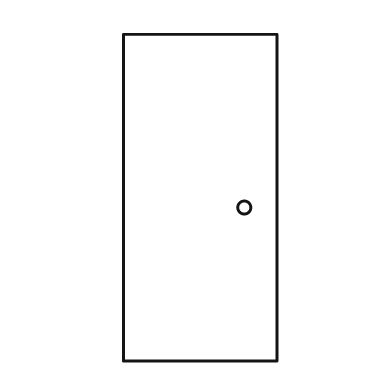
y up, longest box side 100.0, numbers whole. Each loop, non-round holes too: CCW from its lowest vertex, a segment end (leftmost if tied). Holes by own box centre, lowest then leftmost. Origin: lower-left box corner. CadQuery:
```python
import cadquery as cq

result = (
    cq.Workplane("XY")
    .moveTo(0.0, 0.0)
    .lineTo(47.0, 0.0)
    .lineTo(47.0, 100.0)
    .lineTo(0.0, 100.0)
    .close()
    .moveTo(37.0, 47.0)
    .circle(2.0)
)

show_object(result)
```